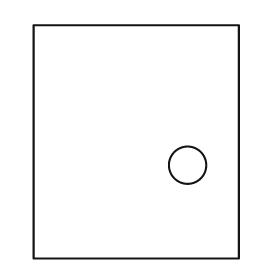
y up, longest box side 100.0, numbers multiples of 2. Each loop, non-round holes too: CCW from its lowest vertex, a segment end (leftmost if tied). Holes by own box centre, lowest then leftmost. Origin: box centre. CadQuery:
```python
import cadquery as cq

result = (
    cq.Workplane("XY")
    .moveTo(-44.0, -50.0)
    .lineTo(44.0, -50.0)
    .lineTo(44.0, 50.0)
    .lineTo(-44.0, 50.0)
    .close()
    .moveTo(22.0, -10.0)
    .circle(8.0)
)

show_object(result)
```